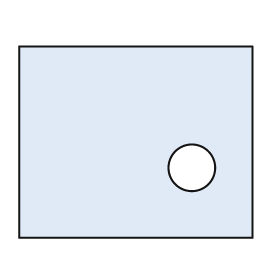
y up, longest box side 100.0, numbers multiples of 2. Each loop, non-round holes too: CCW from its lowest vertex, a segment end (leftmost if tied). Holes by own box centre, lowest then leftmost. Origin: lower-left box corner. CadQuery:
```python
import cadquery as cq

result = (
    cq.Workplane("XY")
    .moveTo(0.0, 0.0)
    .lineTo(100.0, 0.0)
    .lineTo(100.0, 82.0)
    .lineTo(0.0, 82.0)
    .close()
    .moveTo(74.0, 30.0)
    .circle(10.0)
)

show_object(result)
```